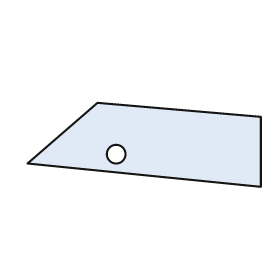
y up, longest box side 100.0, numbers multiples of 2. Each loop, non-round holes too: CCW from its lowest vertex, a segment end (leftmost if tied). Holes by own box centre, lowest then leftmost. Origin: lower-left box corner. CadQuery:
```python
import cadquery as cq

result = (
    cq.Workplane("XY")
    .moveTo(100.0, 0.0)
    .lineTo(100.0, 30.0)
    .lineTo(30.0, 36.0)
    .lineTo(0.0, 10.0)
    .close()
    .moveTo(38.0, 14.0)
    .circle(4.0)
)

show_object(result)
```